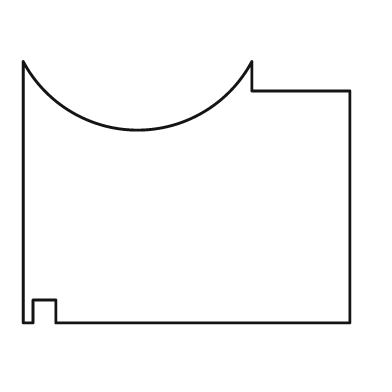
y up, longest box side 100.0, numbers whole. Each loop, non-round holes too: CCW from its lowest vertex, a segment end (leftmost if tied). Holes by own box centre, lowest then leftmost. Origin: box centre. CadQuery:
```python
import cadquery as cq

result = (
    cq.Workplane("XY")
    .moveTo(-50.0, -40.0)
    .lineTo(-47.0, -40.0)
    .lineTo(-47.0, -33.0)
    .lineTo(-40.0, -33.0)
    .lineTo(-40.0, -40.0)
    .lineTo(50.0, -40.0)
    .lineTo(50.0, 31.0)
    .lineTo(20.0, 31.0)
    .lineTo(20.0, 40.0)
    .threePointArc((-15.0, 19.0), (-50.0, 40.0))
    .close()
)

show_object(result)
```